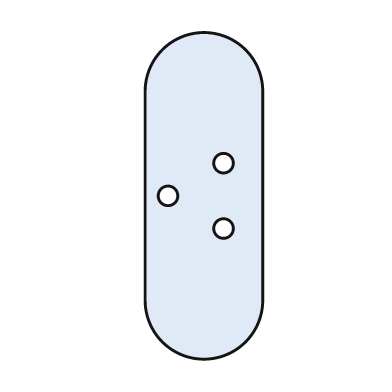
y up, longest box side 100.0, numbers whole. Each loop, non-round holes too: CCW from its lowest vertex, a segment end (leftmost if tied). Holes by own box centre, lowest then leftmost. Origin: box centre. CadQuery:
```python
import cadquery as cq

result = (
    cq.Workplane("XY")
    .moveTo(-18.0, -32.0)
    .threePointArc((0.0, -50.0), (18.0, -32.0))
    .lineTo(18.0, 32.0)
    .threePointArc((0.0, 50.0), (-18.0, 32.0))
    .close()
    .moveTo(6.0, -10.0)
    .circle(3.0)
    .moveTo(-11.0, 0.0)
    .circle(3.0)
    .moveTo(6.0, 10.0)
    .circle(3.0)
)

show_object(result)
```